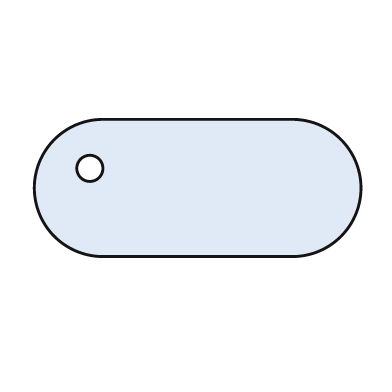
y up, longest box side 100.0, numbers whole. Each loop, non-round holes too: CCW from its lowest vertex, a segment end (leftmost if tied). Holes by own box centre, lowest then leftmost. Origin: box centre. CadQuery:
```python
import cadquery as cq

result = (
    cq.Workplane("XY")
    .moveTo(-29.0, -21.0)
    .lineTo(29.0, -21.0)
    .threePointArc((50.0, 0.0), (29.0, 21.0))
    .lineTo(-29.0, 21.0)
    .threePointArc((-50.0, 0.0), (-29.0, -21.0))
    .close()
    .moveTo(-33.0, 6.0)
    .circle(4.0)
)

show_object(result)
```